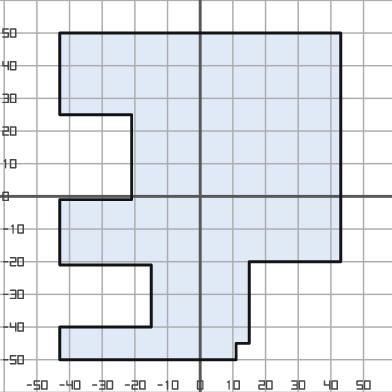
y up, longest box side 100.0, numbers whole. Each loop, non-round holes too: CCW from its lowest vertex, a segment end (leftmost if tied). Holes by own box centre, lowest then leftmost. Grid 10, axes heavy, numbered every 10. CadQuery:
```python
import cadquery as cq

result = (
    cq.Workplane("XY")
    .moveTo(-43.0, -50.0)
    .lineTo(11.0, -50.0)
    .lineTo(11.0, -45.0)
    .lineTo(15.0, -45.0)
    .lineTo(15.0, -20.0)
    .lineTo(43.0, -20.0)
    .lineTo(43.0, 50.0)
    .lineTo(-43.0, 50.0)
    .lineTo(-43.0, 25.0)
    .lineTo(-21.0, 25.0)
    .lineTo(-21.0, -1.0)
    .lineTo(-43.0, -1.0)
    .lineTo(-43.0, -21.0)
    .lineTo(-15.0, -21.0)
    .lineTo(-15.0, -40.0)
    .lineTo(-43.0, -40.0)
    .close()
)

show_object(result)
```